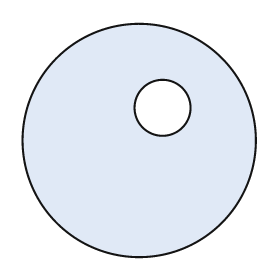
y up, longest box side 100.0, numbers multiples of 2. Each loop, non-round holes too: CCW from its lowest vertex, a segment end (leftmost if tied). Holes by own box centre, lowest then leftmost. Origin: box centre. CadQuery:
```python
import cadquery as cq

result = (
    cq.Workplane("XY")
    .moveTo(0.0, 0.0)
    .circle(50.0)
    .moveTo(10.0, 14.0)
    .circle(12.0)
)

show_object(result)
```